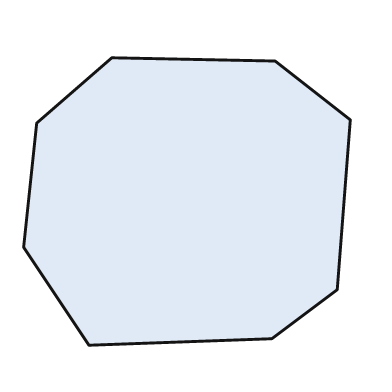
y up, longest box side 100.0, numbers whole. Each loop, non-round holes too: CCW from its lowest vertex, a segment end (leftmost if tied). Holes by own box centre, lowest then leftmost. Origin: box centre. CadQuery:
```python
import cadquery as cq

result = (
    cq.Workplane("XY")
    .moveTo(-30.0, -44.0)
    .lineTo(26.0, -42.0)
    .lineTo(46.0, -27.0)
    .lineTo(50.0, 25.0)
    .lineTo(27.0, 43.0)
    .lineTo(-23.0, 44.0)
    .lineTo(-46.0, 24.0)
    .lineTo(-50.0, -14.0)
    .close()
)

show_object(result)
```